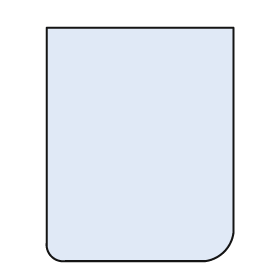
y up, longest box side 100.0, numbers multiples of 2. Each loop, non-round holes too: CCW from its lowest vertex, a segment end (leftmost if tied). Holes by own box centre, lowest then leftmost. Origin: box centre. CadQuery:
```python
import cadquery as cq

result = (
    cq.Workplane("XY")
    .moveTo(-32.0, -50.0)
    .lineTo(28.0, -50.0)
    .threePointArc((36.0, -46.0), (40.0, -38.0))
    .lineTo(40.0, 50.0)
    .lineTo(-40.0, 50.0)
    .lineTo(-40.0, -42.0)
    .threePointArc((-38.0, -48.0), (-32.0, -50.0))
    .close()
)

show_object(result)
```